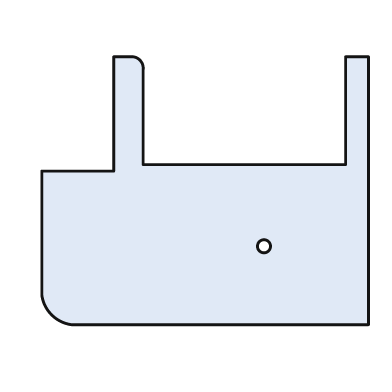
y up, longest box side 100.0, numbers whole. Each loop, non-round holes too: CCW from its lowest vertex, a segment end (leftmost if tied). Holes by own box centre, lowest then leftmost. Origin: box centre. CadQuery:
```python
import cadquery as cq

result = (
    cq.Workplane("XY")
    .moveTo(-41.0, -41.0)
    .lineTo(50.0, -41.0)
    .lineTo(50.0, 41.0)
    .lineTo(43.0, 41.0)
    .lineTo(43.0, 8.0)
    .lineTo(-19.0, 8.0)
    .lineTo(-19.0, 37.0)
    .threePointArc((-20.0, 40.0), (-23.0, 41.0))
    .lineTo(-28.0, 41.0)
    .lineTo(-28.0, 6.0)
    .lineTo(-50.0, 6.0)
    .lineTo(-50.0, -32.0)
    .threePointArc((-47.0, -38.0), (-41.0, -41.0))
    .close()
    .moveTo(18.0, -17.0)
    .circle(2.0)
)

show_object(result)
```